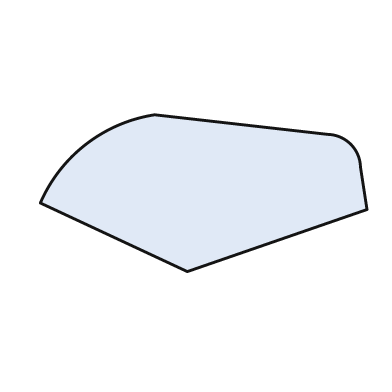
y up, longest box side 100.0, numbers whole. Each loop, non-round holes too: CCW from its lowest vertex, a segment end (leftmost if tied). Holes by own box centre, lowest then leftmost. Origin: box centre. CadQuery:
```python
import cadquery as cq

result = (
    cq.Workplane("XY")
    .moveTo(-5.0, -24.0)
    .lineTo(50.0, -5.0)
    .lineTo(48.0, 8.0)
    .threePointArc((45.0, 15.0), (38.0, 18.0))
    .lineTo(-15.0, 24.0)
    .threePointArc((-36.0, 15.0), (-50.0, -3.0))
    .close()
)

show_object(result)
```